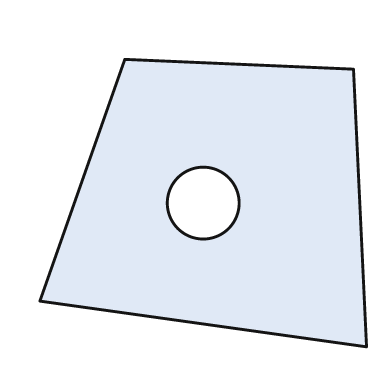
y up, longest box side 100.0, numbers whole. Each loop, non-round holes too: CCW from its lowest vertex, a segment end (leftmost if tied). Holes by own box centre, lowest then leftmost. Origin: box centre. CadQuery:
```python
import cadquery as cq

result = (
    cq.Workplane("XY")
    .moveTo(50.0, -44.0)
    .lineTo(46.0, 41.0)
    .lineTo(-24.0, 44.0)
    .lineTo(-50.0, -30.0)
    .close()
    .moveTo(0.0, 0.0)
    .circle(11.0)
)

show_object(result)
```